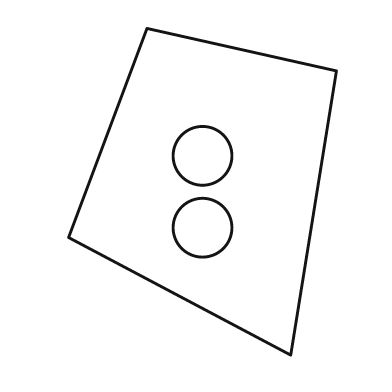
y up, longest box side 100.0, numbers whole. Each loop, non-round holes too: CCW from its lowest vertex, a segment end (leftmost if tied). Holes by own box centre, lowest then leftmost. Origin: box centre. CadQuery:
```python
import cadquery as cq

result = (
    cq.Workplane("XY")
    .moveTo(27.0, -50.0)
    .lineTo(41.0, 37.0)
    .lineTo(-17.0, 50.0)
    .lineTo(-41.0, -14.0)
    .close()
    .moveTo(0.0, -11.0)
    .circle(9.0)
    .moveTo(0.0, 11.0)
    .circle(9.0)
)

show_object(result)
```